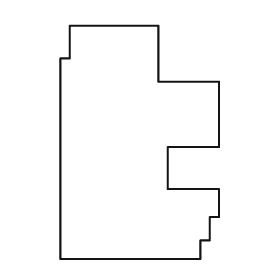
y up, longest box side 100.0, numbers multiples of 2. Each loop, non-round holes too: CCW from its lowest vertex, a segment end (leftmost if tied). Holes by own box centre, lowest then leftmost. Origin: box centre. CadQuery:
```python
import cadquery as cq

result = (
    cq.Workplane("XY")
    .moveTo(-34.0, -50.0)
    .lineTo(26.0, -50.0)
    .lineTo(26.0, -42.0)
    .lineTo(30.0, -42.0)
    .lineTo(30.0, -32.0)
    .lineTo(34.0, -32.0)
    .lineTo(34.0, -20.0)
    .lineTo(12.0, -20.0)
    .lineTo(12.0, -2.0)
    .lineTo(34.0, -2.0)
    .lineTo(34.0, 26.0)
    .lineTo(8.0, 26.0)
    .lineTo(8.0, 50.0)
    .lineTo(-30.0, 50.0)
    .lineTo(-30.0, 36.0)
    .lineTo(-34.0, 36.0)
    .close()
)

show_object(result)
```